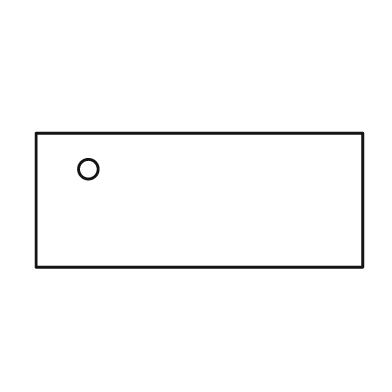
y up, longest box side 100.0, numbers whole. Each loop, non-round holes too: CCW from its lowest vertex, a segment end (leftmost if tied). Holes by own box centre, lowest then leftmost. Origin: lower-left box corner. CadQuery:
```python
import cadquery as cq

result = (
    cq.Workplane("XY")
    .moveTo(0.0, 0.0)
    .lineTo(100.0, 0.0)
    .lineTo(100.0, 41.0)
    .lineTo(0.0, 41.0)
    .close()
    .moveTo(16.0, 30.0)
    .circle(3.0)
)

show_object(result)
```